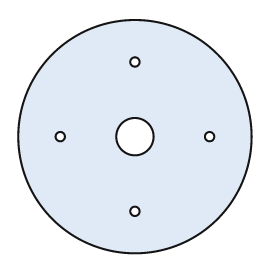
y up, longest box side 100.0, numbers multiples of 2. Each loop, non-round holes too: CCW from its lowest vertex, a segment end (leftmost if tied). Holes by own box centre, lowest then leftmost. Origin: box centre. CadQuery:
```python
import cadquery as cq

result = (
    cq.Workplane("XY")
    .moveTo(0.0, 0.0)
    .circle(50.0)
    .moveTo(0.0, -32.0)
    .circle(2.0)
    .moveTo(-32.0, 0.0)
    .circle(2.0)
    .moveTo(0.0, 0.0)
    .circle(8.0)
    .moveTo(32.0, 0.0)
    .circle(2.0)
    .moveTo(0.0, 32.0)
    .circle(2.0)
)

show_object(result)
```